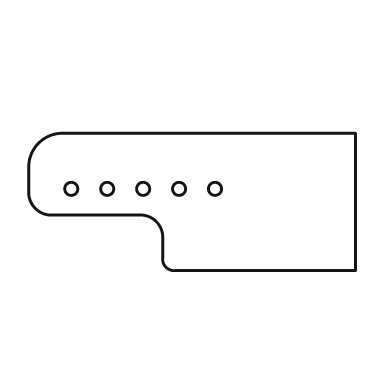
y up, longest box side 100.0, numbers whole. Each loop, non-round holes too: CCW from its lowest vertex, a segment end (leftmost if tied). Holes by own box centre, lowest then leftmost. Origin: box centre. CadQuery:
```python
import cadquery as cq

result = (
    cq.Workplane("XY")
    .moveTo(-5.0, -21.0)
    .lineTo(50.0, -21.0)
    .lineTo(50.0, 21.0)
    .lineTo(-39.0, 21.0)
    .threePointArc((-47.0, 18.0), (-50.0, 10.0))
    .lineTo(-50.0, 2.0)
    .threePointArc((-48.0, -2.0), (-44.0, -4.0))
    .lineTo(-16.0, -4.0)
    .threePointArc((-11.0, -6.0), (-9.0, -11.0))
    .lineTo(-9.0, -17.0)
    .threePointArc((-8.0, -20.0), (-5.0, -21.0))
    .close()
    .moveTo(-37.0, 4.0)
    .circle(2.0)
    .moveTo(-26.0, 4.0)
    .circle(2.0)
    .moveTo(-15.0, 4.0)
    .circle(2.0)
    .moveTo(-4.0, 4.0)
    .circle(2.0)
    .moveTo(7.0, 4.0)
    .circle(2.0)
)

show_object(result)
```